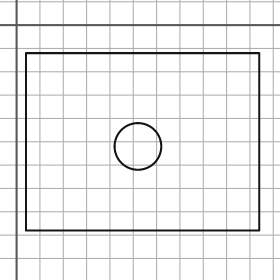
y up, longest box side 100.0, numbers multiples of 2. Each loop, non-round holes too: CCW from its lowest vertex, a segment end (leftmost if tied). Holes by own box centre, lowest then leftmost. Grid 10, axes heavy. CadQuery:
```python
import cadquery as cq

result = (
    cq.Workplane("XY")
    .moveTo(4.0, -88.0)
    .lineTo(104.0, -88.0)
    .lineTo(104.0, -12.0)
    .lineTo(4.0, -12.0)
    .close()
    .moveTo(52.0, -52.0)
    .circle(10.0)
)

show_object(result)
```